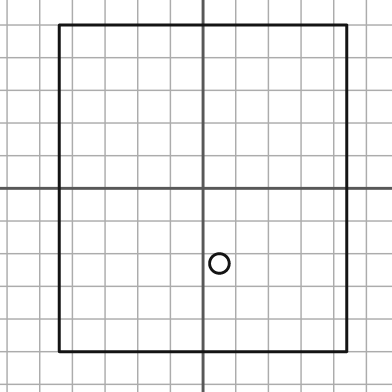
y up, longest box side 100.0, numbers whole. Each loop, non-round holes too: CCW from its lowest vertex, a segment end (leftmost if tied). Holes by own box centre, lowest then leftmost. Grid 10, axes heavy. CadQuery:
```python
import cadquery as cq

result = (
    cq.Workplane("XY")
    .moveTo(-44.0, -50.0)
    .lineTo(44.0, -50.0)
    .lineTo(44.0, 50.0)
    .lineTo(-44.0, 50.0)
    .close()
    .moveTo(5.0, -23.0)
    .circle(3.0)
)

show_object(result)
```